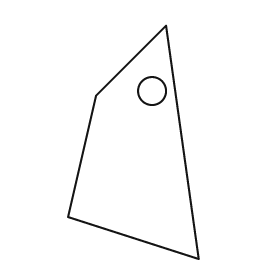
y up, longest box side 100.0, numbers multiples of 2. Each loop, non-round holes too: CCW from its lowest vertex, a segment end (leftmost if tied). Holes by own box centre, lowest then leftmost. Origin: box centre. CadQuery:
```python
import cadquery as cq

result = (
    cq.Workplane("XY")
    .moveTo(28.0, -50.0)
    .lineTo(14.0, 50.0)
    .lineTo(-16.0, 20.0)
    .lineTo(-28.0, -32.0)
    .close()
    .moveTo(8.0, 22.0)
    .circle(6.0)
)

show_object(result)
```